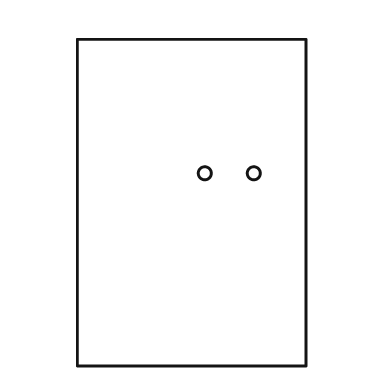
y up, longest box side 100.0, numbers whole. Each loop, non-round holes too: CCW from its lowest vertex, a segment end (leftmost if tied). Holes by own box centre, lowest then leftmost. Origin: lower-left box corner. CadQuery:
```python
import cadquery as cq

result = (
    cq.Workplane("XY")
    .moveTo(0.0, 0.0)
    .lineTo(70.0, 0.0)
    .lineTo(70.0, 100.0)
    .lineTo(0.0, 100.0)
    .close()
    .moveTo(39.0, 59.0)
    .circle(2.0)
    .moveTo(54.0, 59.0)
    .circle(2.0)
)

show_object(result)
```